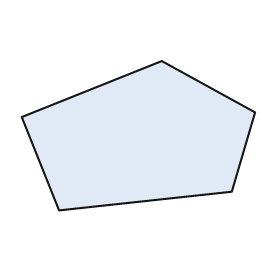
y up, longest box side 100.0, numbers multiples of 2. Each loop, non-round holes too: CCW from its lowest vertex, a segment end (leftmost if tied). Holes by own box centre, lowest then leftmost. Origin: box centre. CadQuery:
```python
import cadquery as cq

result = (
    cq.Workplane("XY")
    .moveTo(-34.0, -32.0)
    .lineTo(40.0, -24.0)
    .lineTo(50.0, 10.0)
    .lineTo(10.0, 32.0)
    .lineTo(-50.0, 8.0)
    .close()
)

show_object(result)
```